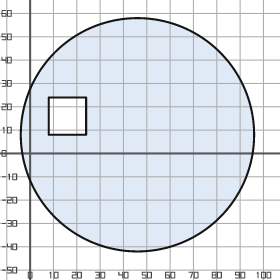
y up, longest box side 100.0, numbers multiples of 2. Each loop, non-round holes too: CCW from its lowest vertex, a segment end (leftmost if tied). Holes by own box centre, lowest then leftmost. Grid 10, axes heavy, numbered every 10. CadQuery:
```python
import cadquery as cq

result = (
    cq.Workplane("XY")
    .moveTo(46.0, 8.0)
    .circle(50.0)
    .moveTo(8.0, 8.0)
    .lineTo(24.0, 8.0)
    .lineTo(24.0, 24.0)
    .lineTo(8.0, 24.0)
    .close()
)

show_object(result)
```